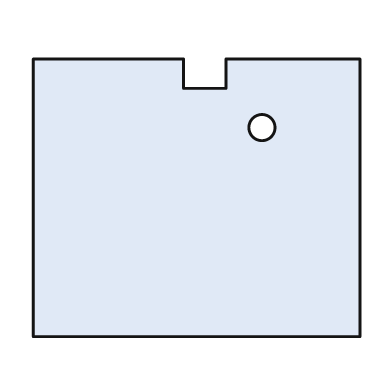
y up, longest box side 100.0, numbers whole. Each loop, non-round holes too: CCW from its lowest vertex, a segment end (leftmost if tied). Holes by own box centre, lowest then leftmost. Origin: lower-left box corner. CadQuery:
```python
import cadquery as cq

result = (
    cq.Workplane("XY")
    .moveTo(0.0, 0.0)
    .lineTo(100.0, 0.0)
    .lineTo(100.0, 85.0)
    .lineTo(59.0, 85.0)
    .lineTo(59.0, 76.0)
    .lineTo(46.0, 76.0)
    .lineTo(46.0, 85.0)
    .lineTo(0.0, 85.0)
    .close()
    .moveTo(70.0, 64.0)
    .circle(4.0)
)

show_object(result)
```